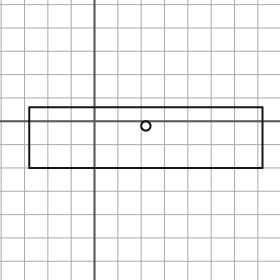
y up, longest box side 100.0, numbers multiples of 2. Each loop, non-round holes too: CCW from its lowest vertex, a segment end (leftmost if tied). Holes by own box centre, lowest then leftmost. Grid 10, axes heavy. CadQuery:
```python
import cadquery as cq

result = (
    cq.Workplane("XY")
    .moveTo(-28.0, -20.0)
    .lineTo(72.0, -20.0)
    .lineTo(72.0, 6.0)
    .lineTo(-28.0, 6.0)
    .close()
    .moveTo(22.0, -2.0)
    .circle(2.0)
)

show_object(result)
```